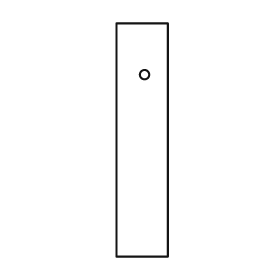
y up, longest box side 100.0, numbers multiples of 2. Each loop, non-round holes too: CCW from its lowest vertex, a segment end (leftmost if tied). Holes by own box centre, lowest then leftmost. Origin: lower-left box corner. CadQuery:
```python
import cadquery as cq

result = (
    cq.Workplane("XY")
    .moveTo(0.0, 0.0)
    .lineTo(22.0, 0.0)
    .lineTo(22.0, 100.0)
    .lineTo(0.0, 100.0)
    .close()
    .moveTo(12.0, 78.0)
    .circle(2.0)
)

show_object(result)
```